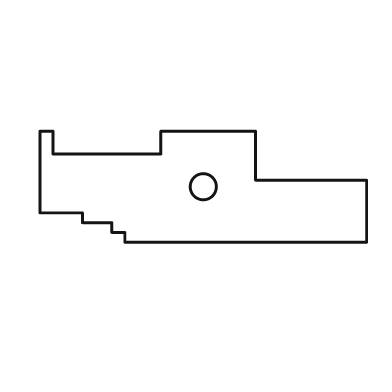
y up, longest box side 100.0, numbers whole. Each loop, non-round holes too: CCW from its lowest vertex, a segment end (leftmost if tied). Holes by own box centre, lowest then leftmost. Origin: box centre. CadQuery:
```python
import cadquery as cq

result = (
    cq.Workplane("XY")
    .moveTo(-24.0, -17.0)
    .lineTo(50.0, -17.0)
    .lineTo(50.0, 2.0)
    .lineTo(16.0, 2.0)
    .lineTo(16.0, 17.0)
    .lineTo(-13.0, 17.0)
    .lineTo(-13.0, 10.0)
    .lineTo(-46.0, 10.0)
    .lineTo(-46.0, 17.0)
    .lineTo(-50.0, 17.0)
    .lineTo(-50.0, -8.0)
    .lineTo(-37.0, -8.0)
    .lineTo(-37.0, -11.0)
    .lineTo(-28.0, -11.0)
    .lineTo(-28.0, -14.0)
    .lineTo(-24.0, -14.0)
    .close()
    .moveTo(0.0, 0.0)
    .circle(4.0)
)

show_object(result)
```